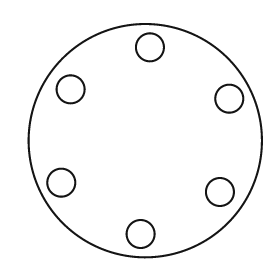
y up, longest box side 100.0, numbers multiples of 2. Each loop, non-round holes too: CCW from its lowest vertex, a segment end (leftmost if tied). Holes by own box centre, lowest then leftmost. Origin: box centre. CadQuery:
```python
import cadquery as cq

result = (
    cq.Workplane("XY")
    .moveTo(0.0, 0.0)
    .circle(50.0)
    .moveTo(-2.0, -40.0)
    .circle(6.0)
    .moveTo(32.0, -22.0)
    .circle(6.0)
    .moveTo(-36.0, -18.0)
    .circle(6.0)
    .moveTo(36.0, 18.0)
    .circle(6.0)
    .moveTo(-32.0, 22.0)
    .circle(6.0)
    .moveTo(2.0, 40.0)
    .circle(6.0)
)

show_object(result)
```